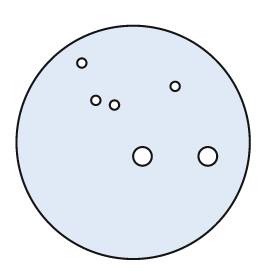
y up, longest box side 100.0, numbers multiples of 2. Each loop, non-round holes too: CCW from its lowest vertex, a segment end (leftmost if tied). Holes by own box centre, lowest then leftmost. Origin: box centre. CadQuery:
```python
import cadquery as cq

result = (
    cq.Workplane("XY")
    .moveTo(0.0, 0.0)
    .circle(50.0)
    .moveTo(4.0, -6.0)
    .circle(4.0)
    .moveTo(32.0, -6.0)
    .circle(4.0)
    .moveTo(-8.0, 16.0)
    .circle(2.0)
    .moveTo(-16.0, 18.0)
    .circle(2.0)
    .moveTo(18.0, 24.0)
    .circle(2.0)
    .moveTo(-22.0, 34.0)
    .circle(2.0)
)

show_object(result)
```